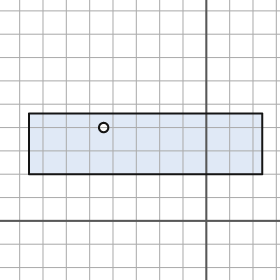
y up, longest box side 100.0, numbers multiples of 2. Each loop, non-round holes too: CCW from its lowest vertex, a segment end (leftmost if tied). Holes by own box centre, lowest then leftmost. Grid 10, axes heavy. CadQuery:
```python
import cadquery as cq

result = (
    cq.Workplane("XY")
    .moveTo(-76.0, 20.0)
    .lineTo(24.0, 20.0)
    .lineTo(24.0, 46.0)
    .lineTo(-76.0, 46.0)
    .close()
    .moveTo(-44.0, 40.0)
    .circle(2.0)
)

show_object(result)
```